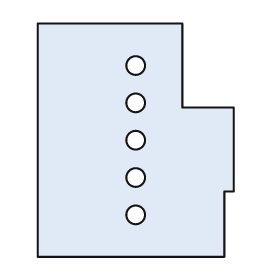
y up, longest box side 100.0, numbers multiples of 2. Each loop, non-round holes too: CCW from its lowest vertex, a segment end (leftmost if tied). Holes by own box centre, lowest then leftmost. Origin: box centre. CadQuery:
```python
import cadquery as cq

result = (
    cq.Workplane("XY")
    .moveTo(-42.0, -50.0)
    .lineTo(38.0, -50.0)
    .lineTo(38.0, -22.0)
    .lineTo(42.0, -22.0)
    .lineTo(42.0, 14.0)
    .lineTo(20.0, 14.0)
    .lineTo(20.0, 50.0)
    .lineTo(-42.0, 50.0)
    .close()
    .moveTo(0.0, -32.0)
    .circle(4.0)
    .moveTo(0.0, -16.0)
    .circle(4.0)
    .moveTo(0.0, 0.0)
    .circle(4.0)
    .moveTo(0.0, 16.0)
    .circle(4.0)
    .moveTo(0.0, 32.0)
    .circle(4.0)
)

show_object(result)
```